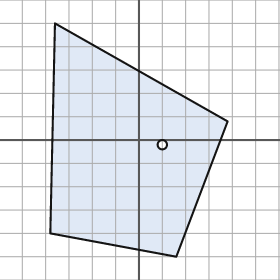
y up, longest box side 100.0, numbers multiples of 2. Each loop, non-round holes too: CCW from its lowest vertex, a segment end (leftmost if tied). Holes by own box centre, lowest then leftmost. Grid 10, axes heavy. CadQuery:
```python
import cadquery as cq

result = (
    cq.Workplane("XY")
    .moveTo(16.0, -50.0)
    .lineTo(38.0, 8.0)
    .lineTo(-36.0, 50.0)
    .lineTo(-38.0, -40.0)
    .close()
    .moveTo(10.0, -2.0)
    .circle(2.0)
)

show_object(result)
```